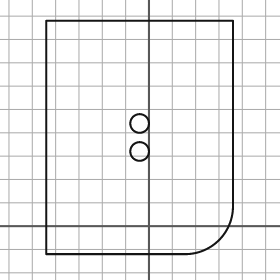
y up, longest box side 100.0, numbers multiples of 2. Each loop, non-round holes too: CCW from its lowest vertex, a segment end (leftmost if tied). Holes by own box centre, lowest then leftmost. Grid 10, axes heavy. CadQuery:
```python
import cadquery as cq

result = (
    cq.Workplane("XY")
    .moveTo(-44.0, -12.0)
    .lineTo(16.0, -12.0)
    .threePointArc((30.0, -6.0), (36.0, 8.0))
    .lineTo(36.0, 88.0)
    .lineTo(-44.0, 88.0)
    .close()
    .moveTo(-4.0, 32.0)
    .circle(4.0)
    .moveTo(-4.0, 44.0)
    .circle(4.0)
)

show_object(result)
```